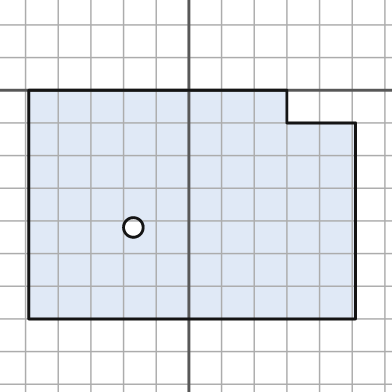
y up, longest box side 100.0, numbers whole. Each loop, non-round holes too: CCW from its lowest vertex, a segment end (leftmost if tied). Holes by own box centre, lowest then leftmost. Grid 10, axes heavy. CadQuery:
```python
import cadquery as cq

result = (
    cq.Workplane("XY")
    .moveTo(-49.0, -70.0)
    .lineTo(51.0, -70.0)
    .lineTo(51.0, -10.0)
    .lineTo(30.0, -10.0)
    .lineTo(30.0, 0.0)
    .lineTo(-49.0, 0.0)
    .close()
    .moveTo(-17.0, -42.0)
    .circle(3.0)
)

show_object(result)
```